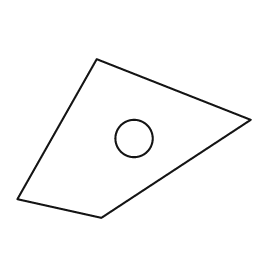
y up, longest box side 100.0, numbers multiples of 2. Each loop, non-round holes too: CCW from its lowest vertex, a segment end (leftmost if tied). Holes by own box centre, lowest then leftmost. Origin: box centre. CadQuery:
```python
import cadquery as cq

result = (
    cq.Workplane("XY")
    .moveTo(-14.0, -34.0)
    .lineTo(50.0, 8.0)
    .lineTo(-16.0, 34.0)
    .lineTo(-50.0, -26.0)
    .close()
    .moveTo(0.0, 0.0)
    .circle(8.0)
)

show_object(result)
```